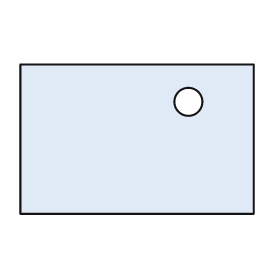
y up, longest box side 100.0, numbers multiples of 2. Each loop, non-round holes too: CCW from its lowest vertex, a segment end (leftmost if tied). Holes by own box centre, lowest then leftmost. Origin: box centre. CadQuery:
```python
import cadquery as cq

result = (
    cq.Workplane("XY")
    .moveTo(-50.0, -32.0)
    .lineTo(50.0, -32.0)
    .lineTo(50.0, 32.0)
    .lineTo(-50.0, 32.0)
    .close()
    .moveTo(22.0, 16.0)
    .circle(6.0)
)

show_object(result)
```